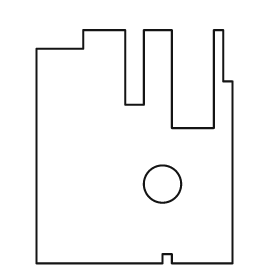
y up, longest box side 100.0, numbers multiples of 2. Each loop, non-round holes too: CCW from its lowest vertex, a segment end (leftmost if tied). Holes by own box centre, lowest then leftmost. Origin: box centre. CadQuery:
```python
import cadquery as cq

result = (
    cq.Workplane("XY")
    .moveTo(-42.0, -50.0)
    .lineTo(12.0, -50.0)
    .lineTo(12.0, -46.0)
    .lineTo(16.0, -46.0)
    .lineTo(16.0, -50.0)
    .lineTo(42.0, -50.0)
    .lineTo(42.0, 28.0)
    .lineTo(38.0, 28.0)
    .lineTo(38.0, 50.0)
    .lineTo(34.0, 50.0)
    .lineTo(34.0, 8.0)
    .lineTo(16.0, 8.0)
    .lineTo(16.0, 50.0)
    .lineTo(4.0, 50.0)
    .lineTo(4.0, 18.0)
    .lineTo(-4.0, 18.0)
    .lineTo(-4.0, 50.0)
    .lineTo(-22.0, 50.0)
    .lineTo(-22.0, 42.0)
    .lineTo(-42.0, 42.0)
    .close()
    .moveTo(12.0, -16.0)
    .circle(8.0)
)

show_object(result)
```